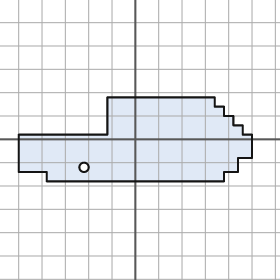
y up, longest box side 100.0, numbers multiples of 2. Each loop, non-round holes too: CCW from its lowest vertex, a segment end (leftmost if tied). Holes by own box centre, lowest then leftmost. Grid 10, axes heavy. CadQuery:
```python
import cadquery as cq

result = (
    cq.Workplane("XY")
    .moveTo(-38.0, -18.0)
    .lineTo(38.0, -18.0)
    .lineTo(38.0, -14.0)
    .lineTo(44.0, -14.0)
    .lineTo(44.0, -8.0)
    .lineTo(50.0, -8.0)
    .lineTo(50.0, 2.0)
    .lineTo(46.0, 2.0)
    .lineTo(46.0, 6.0)
    .lineTo(42.0, 6.0)
    .lineTo(42.0, 10.0)
    .lineTo(38.0, 10.0)
    .lineTo(38.0, 14.0)
    .lineTo(34.0, 14.0)
    .lineTo(34.0, 18.0)
    .lineTo(-12.0, 18.0)
    .lineTo(-12.0, 2.0)
    .lineTo(-50.0, 2.0)
    .lineTo(-50.0, -14.0)
    .lineTo(-38.0, -14.0)
    .close()
    .moveTo(-22.0, -12.0)
    .circle(2.0)
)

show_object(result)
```